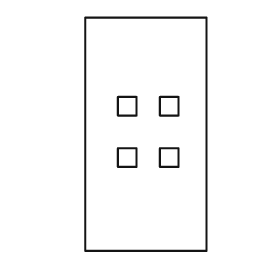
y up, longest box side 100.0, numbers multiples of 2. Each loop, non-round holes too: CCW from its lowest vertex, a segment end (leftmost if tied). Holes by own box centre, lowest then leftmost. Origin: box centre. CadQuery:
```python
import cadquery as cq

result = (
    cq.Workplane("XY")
    .moveTo(-26.0, -50.0)
    .lineTo(26.0, -50.0)
    .lineTo(26.0, 50.0)
    .lineTo(-26.0, 50.0)
    .close()
    .moveTo(-12.0, -14.0)
    .lineTo(-4.0, -14.0)
    .lineTo(-4.0, -6.0)
    .lineTo(-12.0, -6.0)
    .close()
    .moveTo(6.0, -14.0)
    .lineTo(14.0, -14.0)
    .lineTo(14.0, -6.0)
    .lineTo(6.0, -6.0)
    .close()
    .moveTo(-12.0, 8.0)
    .lineTo(-4.0, 8.0)
    .lineTo(-4.0, 16.0)
    .lineTo(-12.0, 16.0)
    .close()
    .moveTo(6.0, 8.0)
    .lineTo(14.0, 8.0)
    .lineTo(14.0, 16.0)
    .lineTo(6.0, 16.0)
    .close()
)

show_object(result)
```